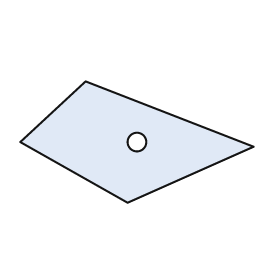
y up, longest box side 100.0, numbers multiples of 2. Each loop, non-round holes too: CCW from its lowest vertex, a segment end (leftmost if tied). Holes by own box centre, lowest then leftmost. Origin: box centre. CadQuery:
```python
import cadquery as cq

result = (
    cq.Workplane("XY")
    .moveTo(-4.0, -26.0)
    .lineTo(50.0, -2.0)
    .lineTo(-22.0, 26.0)
    .lineTo(-50.0, 0.0)
    .close()
    .moveTo(0.0, 0.0)
    .circle(4.0)
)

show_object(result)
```